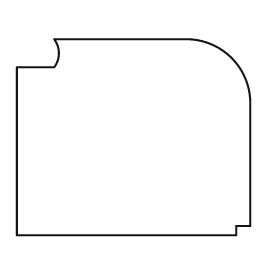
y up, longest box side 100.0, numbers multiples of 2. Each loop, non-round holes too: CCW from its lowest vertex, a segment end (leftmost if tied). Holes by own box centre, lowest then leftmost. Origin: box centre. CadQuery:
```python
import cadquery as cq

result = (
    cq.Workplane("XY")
    .moveTo(-50.0, -42.0)
    .lineTo(44.0, -42.0)
    .lineTo(44.0, -38.0)
    .lineTo(50.0, -38.0)
    .lineTo(50.0, 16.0)
    .threePointArc((42.0, 34.0), (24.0, 42.0))
    .lineTo(-34.0, 42.0)
    .threePointArc((-32.0, 36.0), (-34.0, 30.0))
    .lineTo(-50.0, 30.0)
    .close()
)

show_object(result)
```